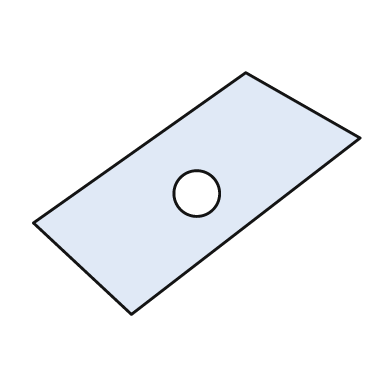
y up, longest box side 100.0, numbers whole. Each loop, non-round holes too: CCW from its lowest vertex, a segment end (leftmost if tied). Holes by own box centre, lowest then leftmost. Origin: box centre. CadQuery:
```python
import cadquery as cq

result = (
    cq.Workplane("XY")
    .moveTo(-20.0, -37.0)
    .lineTo(50.0, 17.0)
    .lineTo(15.0, 37.0)
    .lineTo(-50.0, -9.0)
    .close()
    .moveTo(0.0, 0.0)
    .circle(7.0)
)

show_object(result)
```